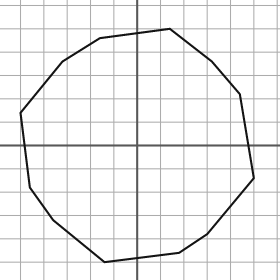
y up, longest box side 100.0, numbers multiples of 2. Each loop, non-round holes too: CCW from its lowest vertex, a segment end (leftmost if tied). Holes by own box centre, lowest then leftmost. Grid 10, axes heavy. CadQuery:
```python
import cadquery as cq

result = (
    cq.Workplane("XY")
    .moveTo(-14.0, -50.0)
    .lineTo(18.0, -46.0)
    .lineTo(30.0, -38.0)
    .lineTo(50.0, -14.0)
    .lineTo(44.0, 22.0)
    .lineTo(32.0, 36.0)
    .lineTo(14.0, 50.0)
    .lineTo(-16.0, 46.0)
    .lineTo(-32.0, 36.0)
    .lineTo(-50.0, 14.0)
    .lineTo(-46.0, -18.0)
    .lineTo(-36.0, -32.0)
    .close()
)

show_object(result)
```